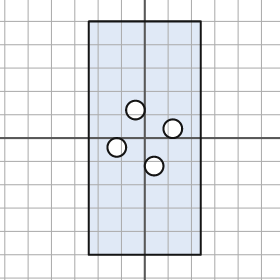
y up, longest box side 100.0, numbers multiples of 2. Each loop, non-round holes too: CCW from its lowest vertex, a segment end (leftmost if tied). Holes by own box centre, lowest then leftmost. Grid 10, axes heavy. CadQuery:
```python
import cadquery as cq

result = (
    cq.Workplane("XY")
    .moveTo(-24.0, -50.0)
    .lineTo(24.0, -50.0)
    .lineTo(24.0, 50.0)
    .lineTo(-24.0, 50.0)
    .close()
    .moveTo(4.0, -12.0)
    .circle(4.0)
    .moveTo(-12.0, -4.0)
    .circle(4.0)
    .moveTo(12.0, 4.0)
    .circle(4.0)
    .moveTo(-4.0, 12.0)
    .circle(4.0)
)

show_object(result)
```